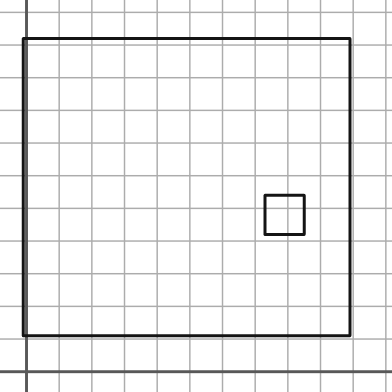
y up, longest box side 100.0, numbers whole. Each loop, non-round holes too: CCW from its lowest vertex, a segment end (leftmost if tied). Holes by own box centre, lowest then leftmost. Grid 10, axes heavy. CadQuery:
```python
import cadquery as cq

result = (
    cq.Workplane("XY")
    .moveTo(-1.0, 11.0)
    .lineTo(99.0, 11.0)
    .lineTo(99.0, 102.0)
    .lineTo(-1.0, 102.0)
    .close()
    .moveTo(73.0, 42.0)
    .lineTo(85.0, 42.0)
    .lineTo(85.0, 54.0)
    .lineTo(73.0, 54.0)
    .close()
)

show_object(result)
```